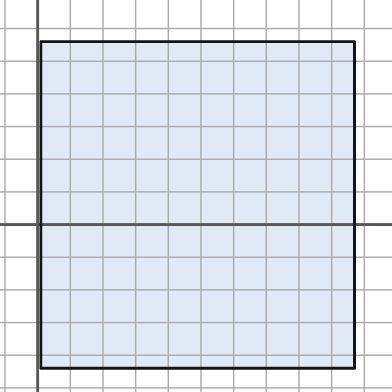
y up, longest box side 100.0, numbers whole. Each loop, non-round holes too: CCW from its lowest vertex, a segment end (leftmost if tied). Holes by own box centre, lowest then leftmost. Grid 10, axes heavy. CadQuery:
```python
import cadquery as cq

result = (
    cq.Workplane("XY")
    .moveTo(1.0, -44.0)
    .lineTo(97.0, -44.0)
    .lineTo(97.0, 56.0)
    .lineTo(1.0, 56.0)
    .close()
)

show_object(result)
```